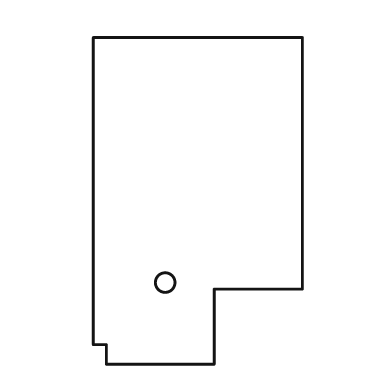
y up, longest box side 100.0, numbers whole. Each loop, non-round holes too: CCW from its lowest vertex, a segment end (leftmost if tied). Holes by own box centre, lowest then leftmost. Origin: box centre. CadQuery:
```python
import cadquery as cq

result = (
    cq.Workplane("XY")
    .moveTo(-28.0, -50.0)
    .lineTo(5.0, -50.0)
    .lineTo(5.0, -27.0)
    .lineTo(32.0, -27.0)
    .lineTo(32.0, 50.0)
    .lineTo(-32.0, 50.0)
    .lineTo(-32.0, -44.0)
    .lineTo(-28.0, -44.0)
    .close()
    .moveTo(-10.0, -25.0)
    .circle(3.0)
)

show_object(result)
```